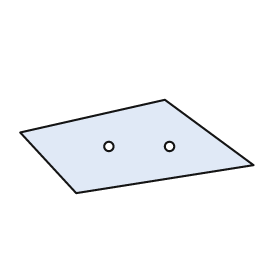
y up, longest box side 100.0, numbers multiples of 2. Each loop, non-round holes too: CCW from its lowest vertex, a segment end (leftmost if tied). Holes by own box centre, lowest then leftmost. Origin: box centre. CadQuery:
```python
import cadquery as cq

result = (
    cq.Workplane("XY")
    .moveTo(-26.0, -20.0)
    .lineTo(50.0, -8.0)
    .lineTo(12.0, 20.0)
    .lineTo(-50.0, 6.0)
    .close()
    .moveTo(-12.0, 0.0)
    .circle(2.0)
    .moveTo(14.0, 0.0)
    .circle(2.0)
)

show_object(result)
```